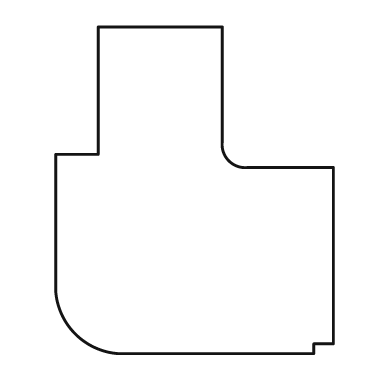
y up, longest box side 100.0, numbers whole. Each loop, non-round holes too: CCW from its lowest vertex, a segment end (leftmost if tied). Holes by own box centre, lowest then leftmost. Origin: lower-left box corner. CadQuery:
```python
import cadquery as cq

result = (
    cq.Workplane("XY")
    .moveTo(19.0, 0.0)
    .lineTo(79.0, 0.0)
    .lineTo(79.0, 3.0)
    .lineTo(85.0, 3.0)
    .lineTo(85.0, 57.0)
    .lineTo(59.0, 57.0)
    .threePointArc((53.0, 59.0), (51.0, 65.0))
    .lineTo(51.0, 100.0)
    .lineTo(13.0, 100.0)
    .lineTo(13.0, 61.0)
    .lineTo(0.0, 61.0)
    .lineTo(0.0, 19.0)
    .threePointArc((6.0, 6.0), (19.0, 0.0))
    .close()
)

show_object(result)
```